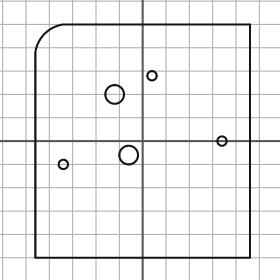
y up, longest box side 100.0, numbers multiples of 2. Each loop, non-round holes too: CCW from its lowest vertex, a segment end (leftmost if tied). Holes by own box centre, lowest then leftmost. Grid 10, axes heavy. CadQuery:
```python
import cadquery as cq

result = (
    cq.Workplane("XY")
    .moveTo(-46.0, -50.0)
    .lineTo(46.0, -50.0)
    .lineTo(46.0, 50.0)
    .lineTo(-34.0, 50.0)
    .threePointArc((-42.0, 46.0), (-46.0, 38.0))
    .close()
    .moveTo(-34.0, -10.0)
    .circle(2.0)
    .moveTo(-6.0, -6.0)
    .circle(4.0)
    .moveTo(34.0, 0.0)
    .circle(2.0)
    .moveTo(-12.0, 20.0)
    .circle(4.0)
    .moveTo(4.0, 28.0)
    .circle(2.0)
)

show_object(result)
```